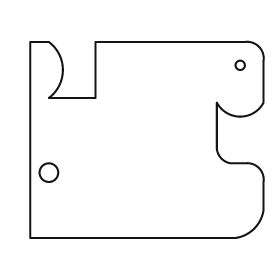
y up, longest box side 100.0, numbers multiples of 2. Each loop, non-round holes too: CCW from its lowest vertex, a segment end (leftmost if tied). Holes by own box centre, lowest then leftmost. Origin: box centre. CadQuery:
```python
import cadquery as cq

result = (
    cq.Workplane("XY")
    .moveTo(-50.0, -42.0)
    .lineTo(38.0, -42.0)
    .threePointArc((46.0, -38.0), (50.0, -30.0))
    .lineTo(50.0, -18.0)
    .threePointArc((48.0, -12.0), (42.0, -10.0))
    .lineTo(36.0, -10.0)
    .threePointArc((32.0, -8.0), (30.0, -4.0))
    .lineTo(30.0, 16.0)
    .threePointArc((40.0, 10.0), (50.0, 16.0))
    .lineTo(50.0, 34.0)
    .threePointArc((48.0, 40.0), (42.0, 42.0))
    .lineTo(-22.0, 42.0)
    .lineTo(-22.0, 18.0)
    .lineTo(-42.0, 18.0)
    .threePointArc((-36.0, 30.0), (-42.0, 42.0))
    .lineTo(-50.0, 42.0)
    .close()
    .moveTo(-42.0, -14.0)
    .circle(4.0)
    .moveTo(40.0, 32.0)
    .circle(2.0)
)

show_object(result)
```